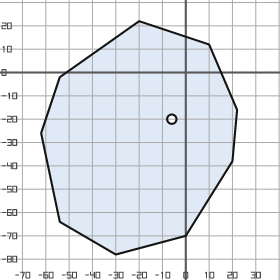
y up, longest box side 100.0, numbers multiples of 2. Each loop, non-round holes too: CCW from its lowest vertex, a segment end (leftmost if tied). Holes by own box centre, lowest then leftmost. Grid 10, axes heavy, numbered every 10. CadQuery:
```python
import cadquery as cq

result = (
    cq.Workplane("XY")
    .moveTo(-30.0, -78.0)
    .lineTo(0.0, -70.0)
    .lineTo(20.0, -38.0)
    .lineTo(22.0, -16.0)
    .lineTo(10.0, 12.0)
    .lineTo(-20.0, 22.0)
    .lineTo(-54.0, -2.0)
    .lineTo(-62.0, -26.0)
    .lineTo(-54.0, -64.0)
    .close()
    .moveTo(-6.0, -20.0)
    .circle(2.0)
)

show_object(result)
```